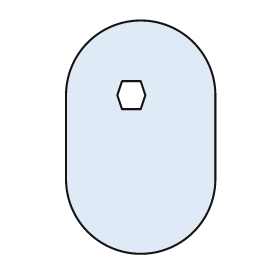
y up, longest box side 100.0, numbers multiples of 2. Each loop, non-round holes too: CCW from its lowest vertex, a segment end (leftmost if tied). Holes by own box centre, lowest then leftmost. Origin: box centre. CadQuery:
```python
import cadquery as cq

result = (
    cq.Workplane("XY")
    .moveTo(-32.0, -18.0)
    .threePointArc((0.0, -50.0), (32.0, -18.0))
    .lineTo(32.0, 18.0)
    .threePointArc((0.0, 50.0), (-32.0, 18.0))
    .close()
    .moveTo(-8.0, 12.0)
    .lineTo(0.0, 12.0)
    .lineTo(2.0, 18.0)
    .lineTo(0.0, 24.0)
    .lineTo(-8.0, 24.0)
    .lineTo(-10.0, 18.0)
    .close()
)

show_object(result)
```